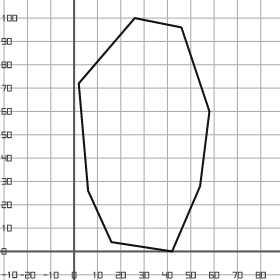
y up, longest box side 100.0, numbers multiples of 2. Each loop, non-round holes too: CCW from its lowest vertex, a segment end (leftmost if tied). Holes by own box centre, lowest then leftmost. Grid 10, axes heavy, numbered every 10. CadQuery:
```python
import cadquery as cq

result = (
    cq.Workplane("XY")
    .moveTo(42.0, 0.0)
    .lineTo(54.0, 28.0)
    .lineTo(58.0, 60.0)
    .lineTo(46.0, 96.0)
    .lineTo(26.0, 100.0)
    .lineTo(2.0, 72.0)
    .lineTo(6.0, 26.0)
    .lineTo(16.0, 4.0)
    .close()
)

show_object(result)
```